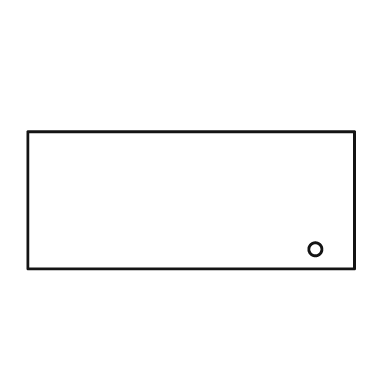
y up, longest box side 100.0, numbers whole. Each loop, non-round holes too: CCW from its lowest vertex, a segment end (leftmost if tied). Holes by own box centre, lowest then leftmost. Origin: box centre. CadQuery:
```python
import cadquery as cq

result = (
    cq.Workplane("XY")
    .moveTo(-50.0, -21.0)
    .lineTo(50.0, -21.0)
    .lineTo(50.0, 21.0)
    .lineTo(-50.0, 21.0)
    .close()
    .moveTo(38.0, -15.0)
    .circle(2.0)
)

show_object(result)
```